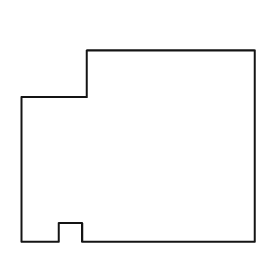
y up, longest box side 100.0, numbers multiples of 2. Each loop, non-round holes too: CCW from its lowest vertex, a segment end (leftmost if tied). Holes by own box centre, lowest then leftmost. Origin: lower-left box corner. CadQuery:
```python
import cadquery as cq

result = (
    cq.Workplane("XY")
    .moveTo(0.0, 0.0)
    .lineTo(16.0, 0.0)
    .lineTo(16.0, 8.0)
    .lineTo(26.0, 8.0)
    .lineTo(26.0, 0.0)
    .lineTo(100.0, 0.0)
    .lineTo(100.0, 82.0)
    .lineTo(28.0, 82.0)
    .lineTo(28.0, 62.0)
    .lineTo(0.0, 62.0)
    .close()
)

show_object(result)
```